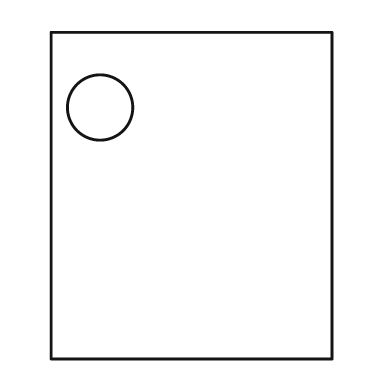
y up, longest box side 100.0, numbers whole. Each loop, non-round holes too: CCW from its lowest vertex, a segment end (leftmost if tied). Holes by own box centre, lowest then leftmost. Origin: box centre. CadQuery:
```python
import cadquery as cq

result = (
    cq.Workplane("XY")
    .moveTo(-43.0, -50.0)
    .lineTo(43.0, -50.0)
    .lineTo(43.0, 50.0)
    .lineTo(-43.0, 50.0)
    .close()
    .moveTo(-28.0, 27.0)
    .circle(10.0)
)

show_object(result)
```